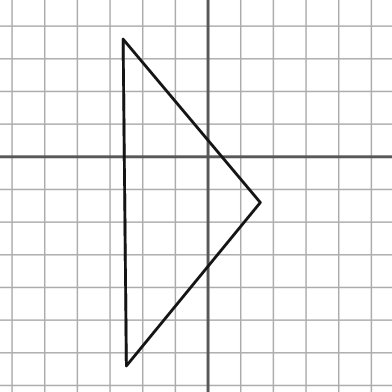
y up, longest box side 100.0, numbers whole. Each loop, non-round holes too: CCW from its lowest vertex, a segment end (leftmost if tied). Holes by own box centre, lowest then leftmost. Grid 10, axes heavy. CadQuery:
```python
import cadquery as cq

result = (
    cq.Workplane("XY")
    .moveTo(-25.0, -64.0)
    .lineTo(16.0, -14.0)
    .lineTo(-26.0, 36.0)
    .close()
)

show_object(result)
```